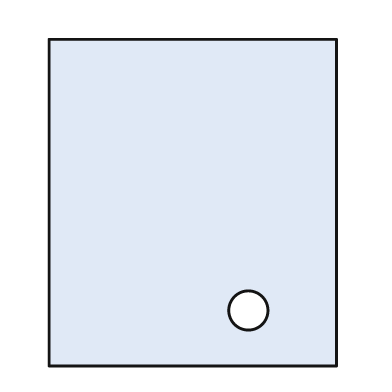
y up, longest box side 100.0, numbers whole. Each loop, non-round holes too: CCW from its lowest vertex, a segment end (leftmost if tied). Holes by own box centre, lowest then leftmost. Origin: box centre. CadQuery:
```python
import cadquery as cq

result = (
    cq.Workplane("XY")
    .moveTo(-44.0, -50.0)
    .lineTo(44.0, -50.0)
    .lineTo(44.0, 50.0)
    .lineTo(-44.0, 50.0)
    .close()
    .moveTo(17.0, -33.0)
    .circle(6.0)
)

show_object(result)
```